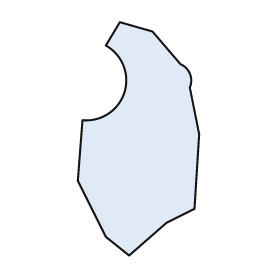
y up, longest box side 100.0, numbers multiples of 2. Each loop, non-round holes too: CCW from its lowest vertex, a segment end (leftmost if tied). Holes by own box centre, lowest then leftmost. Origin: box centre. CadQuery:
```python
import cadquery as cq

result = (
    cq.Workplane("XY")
    .moveTo(-4.0, -50.0)
    .lineTo(12.0, -36.0)
    .lineTo(24.0, -30.0)
    .lineTo(26.0, 2.0)
    .lineTo(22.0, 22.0)
    .threePointArc((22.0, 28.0), (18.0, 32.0))
    .lineTo(6.0, 46.0)
    .lineTo(-8.0, 50.0)
    .lineTo(-14.0, 40.0)
    .threePointArc((-6.0, 20.0), (-24.0, 8.0))
    .lineTo(-26.0, -18.0)
    .lineTo(-14.0, -42.0)
    .close()
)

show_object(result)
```